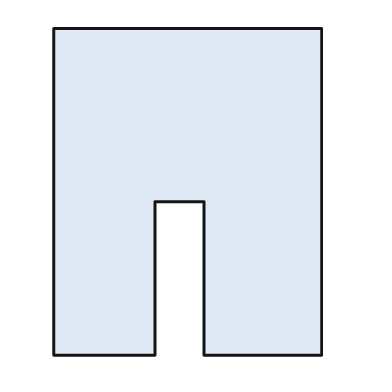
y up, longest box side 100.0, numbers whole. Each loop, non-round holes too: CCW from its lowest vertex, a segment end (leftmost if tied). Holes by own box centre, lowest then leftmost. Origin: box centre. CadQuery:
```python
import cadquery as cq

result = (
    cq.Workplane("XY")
    .moveTo(-41.0, -50.0)
    .lineTo(-10.0, -50.0)
    .lineTo(-10.0, -3.0)
    .lineTo(5.0, -3.0)
    .lineTo(5.0, -50.0)
    .lineTo(41.0, -50.0)
    .lineTo(41.0, 50.0)
    .lineTo(-41.0, 50.0)
    .close()
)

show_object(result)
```